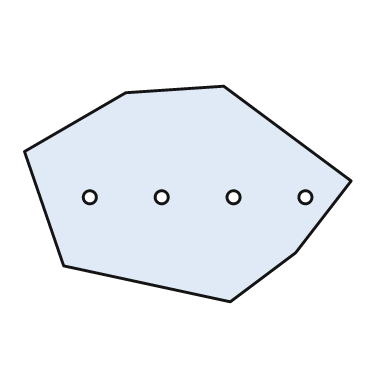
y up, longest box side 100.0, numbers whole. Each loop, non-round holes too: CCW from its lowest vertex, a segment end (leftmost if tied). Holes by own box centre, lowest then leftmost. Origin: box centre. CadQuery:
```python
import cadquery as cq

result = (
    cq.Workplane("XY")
    .moveTo(13.0, -33.0)
    .lineTo(33.0, -18.0)
    .lineTo(50.0, 4.0)
    .lineTo(11.0, 33.0)
    .lineTo(-19.0, 31.0)
    .lineTo(-50.0, 13.0)
    .lineTo(-38.0, -22.0)
    .close()
    .moveTo(-30.0, -1.0)
    .circle(2.0)
    .moveTo(-8.0, -1.0)
    .circle(2.0)
    .moveTo(14.0, -1.0)
    .circle(2.0)
    .moveTo(36.0, -1.0)
    .circle(2.0)
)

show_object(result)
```